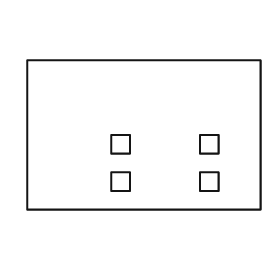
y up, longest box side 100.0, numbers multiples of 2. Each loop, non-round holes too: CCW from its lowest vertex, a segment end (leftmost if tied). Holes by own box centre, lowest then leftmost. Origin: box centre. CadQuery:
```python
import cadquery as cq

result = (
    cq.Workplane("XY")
    .moveTo(-50.0, -32.0)
    .lineTo(50.0, -32.0)
    .lineTo(50.0, 32.0)
    .lineTo(-50.0, 32.0)
    .close()
    .moveTo(-14.0, -24.0)
    .lineTo(-6.0, -24.0)
    .lineTo(-6.0, -16.0)
    .lineTo(-14.0, -16.0)
    .close()
    .moveTo(24.0, -24.0)
    .lineTo(32.0, -24.0)
    .lineTo(32.0, -16.0)
    .lineTo(24.0, -16.0)
    .close()
    .moveTo(-14.0, -8.0)
    .lineTo(-6.0, -8.0)
    .lineTo(-6.0, 0.0)
    .lineTo(-14.0, 0.0)
    .close()
    .moveTo(24.0, -8.0)
    .lineTo(32.0, -8.0)
    .lineTo(32.0, 0.0)
    .lineTo(24.0, 0.0)
    .close()
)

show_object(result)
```